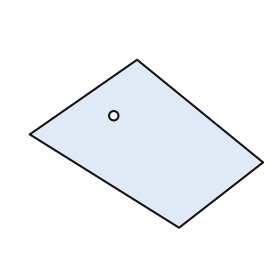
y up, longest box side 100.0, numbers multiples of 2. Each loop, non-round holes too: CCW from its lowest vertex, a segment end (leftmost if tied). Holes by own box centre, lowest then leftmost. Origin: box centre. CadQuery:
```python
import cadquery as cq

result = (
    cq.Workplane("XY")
    .moveTo(14.0, -36.0)
    .lineTo(50.0, -8.0)
    .lineTo(-4.0, 36.0)
    .lineTo(-50.0, 4.0)
    .close()
    .moveTo(-14.0, 12.0)
    .circle(2.0)
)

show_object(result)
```